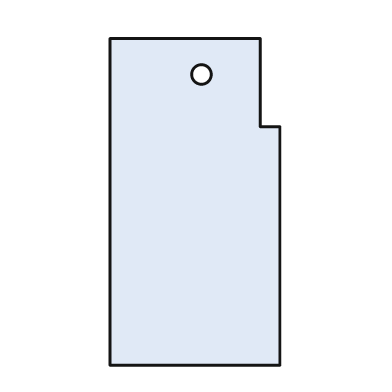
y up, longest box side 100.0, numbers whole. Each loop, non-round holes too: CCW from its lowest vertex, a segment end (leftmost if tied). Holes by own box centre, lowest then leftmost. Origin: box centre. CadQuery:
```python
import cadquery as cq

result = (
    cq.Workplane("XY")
    .moveTo(-26.0, -50.0)
    .lineTo(26.0, -50.0)
    .lineTo(26.0, 23.0)
    .lineTo(20.0, 23.0)
    .lineTo(20.0, 50.0)
    .lineTo(-26.0, 50.0)
    .close()
    .moveTo(2.0, 39.0)
    .circle(3.0)
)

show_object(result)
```